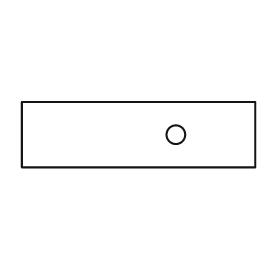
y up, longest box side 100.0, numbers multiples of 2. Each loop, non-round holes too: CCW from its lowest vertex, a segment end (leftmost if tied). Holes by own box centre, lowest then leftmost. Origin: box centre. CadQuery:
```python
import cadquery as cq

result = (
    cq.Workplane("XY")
    .moveTo(-50.0, -14.0)
    .lineTo(50.0, -14.0)
    .lineTo(50.0, 14.0)
    .lineTo(-50.0, 14.0)
    .close()
    .moveTo(16.0, 0.0)
    .circle(4.0)
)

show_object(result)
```